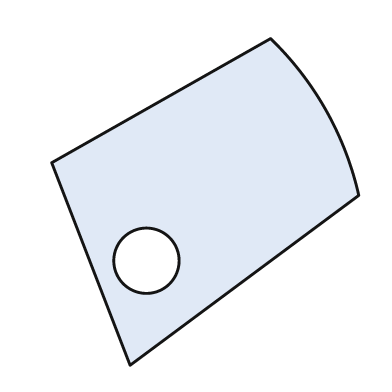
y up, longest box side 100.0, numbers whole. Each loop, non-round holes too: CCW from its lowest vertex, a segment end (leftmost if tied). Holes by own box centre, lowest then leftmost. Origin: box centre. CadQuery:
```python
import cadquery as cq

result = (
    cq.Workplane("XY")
    .moveTo(-23.0, -50.0)
    .lineTo(47.0, 2.0)
    .threePointArc((37.0, 28.0), (20.0, 50.0))
    .lineTo(-47.0, 12.0)
    .close()
    .moveTo(-18.0, -18.0)
    .circle(10.0)
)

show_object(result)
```